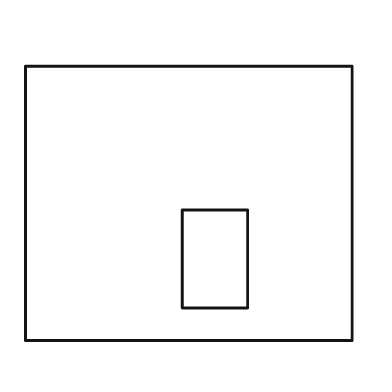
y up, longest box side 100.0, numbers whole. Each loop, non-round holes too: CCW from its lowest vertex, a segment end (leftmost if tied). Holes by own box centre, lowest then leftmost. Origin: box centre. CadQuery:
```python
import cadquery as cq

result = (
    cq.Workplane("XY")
    .moveTo(-50.0, -42.0)
    .lineTo(50.0, -42.0)
    .lineTo(50.0, 42.0)
    .lineTo(-50.0, 42.0)
    .close()
    .moveTo(-2.0, -32.0)
    .lineTo(18.0, -32.0)
    .lineTo(18.0, -2.0)
    .lineTo(-2.0, -2.0)
    .close()
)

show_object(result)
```